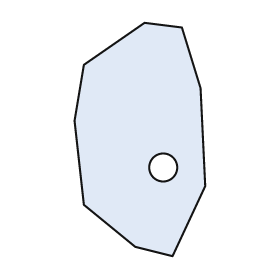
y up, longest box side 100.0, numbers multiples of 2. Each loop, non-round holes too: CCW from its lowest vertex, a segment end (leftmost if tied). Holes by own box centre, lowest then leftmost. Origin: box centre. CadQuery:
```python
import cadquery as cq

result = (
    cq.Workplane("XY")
    .moveTo(14.0, -50.0)
    .lineTo(28.0, -20.0)
    .lineTo(26.0, 22.0)
    .lineTo(18.0, 48.0)
    .lineTo(2.0, 50.0)
    .lineTo(-24.0, 32.0)
    .lineTo(-28.0, 8.0)
    .lineTo(-24.0, -28.0)
    .lineTo(-2.0, -46.0)
    .close()
    .moveTo(10.0, -12.0)
    .circle(6.0)
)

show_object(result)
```